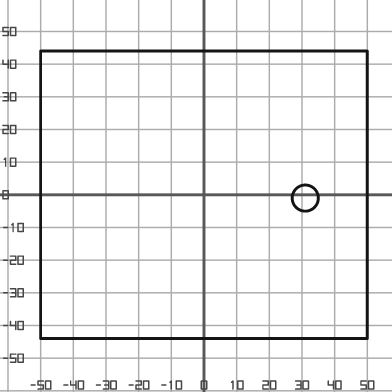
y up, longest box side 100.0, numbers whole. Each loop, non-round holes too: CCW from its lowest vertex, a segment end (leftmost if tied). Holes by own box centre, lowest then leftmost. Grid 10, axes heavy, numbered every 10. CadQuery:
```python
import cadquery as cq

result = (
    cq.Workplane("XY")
    .moveTo(-50.0, -44.0)
    .lineTo(50.0, -44.0)
    .lineTo(50.0, 44.0)
    .lineTo(-50.0, 44.0)
    .close()
    .moveTo(31.0, -1.0)
    .circle(4.0)
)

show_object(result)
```